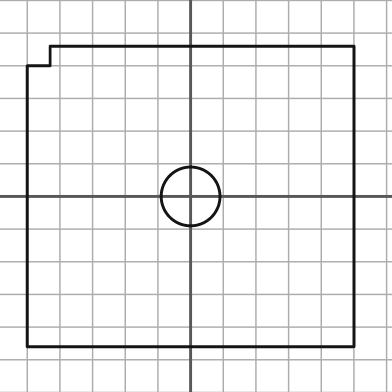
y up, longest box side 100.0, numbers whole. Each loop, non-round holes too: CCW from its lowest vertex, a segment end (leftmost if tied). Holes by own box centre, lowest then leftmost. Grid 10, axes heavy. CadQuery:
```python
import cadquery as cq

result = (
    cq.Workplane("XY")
    .moveTo(-50.0, -46.0)
    .lineTo(50.0, -46.0)
    .lineTo(50.0, 46.0)
    .lineTo(-43.0, 46.0)
    .lineTo(-43.0, 40.0)
    .lineTo(-50.0, 40.0)
    .close()
    .moveTo(0.0, 0.0)
    .circle(9.0)
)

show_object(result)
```